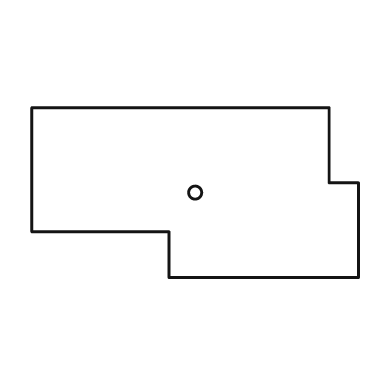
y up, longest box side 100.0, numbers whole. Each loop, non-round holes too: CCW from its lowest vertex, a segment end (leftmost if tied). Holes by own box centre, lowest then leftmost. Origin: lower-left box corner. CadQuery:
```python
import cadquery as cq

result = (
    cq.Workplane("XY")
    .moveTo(42.0, 0.0)
    .lineTo(100.0, 0.0)
    .lineTo(100.0, 29.0)
    .lineTo(91.0, 29.0)
    .lineTo(91.0, 52.0)
    .lineTo(0.0, 52.0)
    .lineTo(0.0, 14.0)
    .lineTo(42.0, 14.0)
    .close()
    .moveTo(50.0, 26.0)
    .circle(2.0)
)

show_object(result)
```